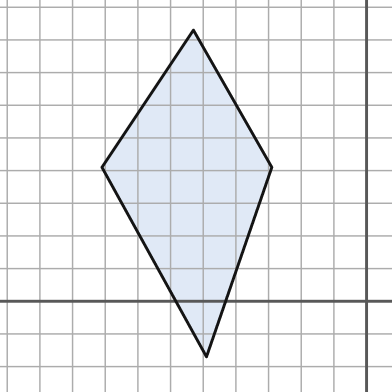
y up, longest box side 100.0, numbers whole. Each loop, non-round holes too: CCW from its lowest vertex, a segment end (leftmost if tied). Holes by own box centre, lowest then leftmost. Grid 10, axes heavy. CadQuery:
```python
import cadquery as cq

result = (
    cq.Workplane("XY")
    .moveTo(-49.0, -17.0)
    .lineTo(-29.0, 41.0)
    .lineTo(-53.0, 83.0)
    .lineTo(-81.0, 41.0)
    .close()
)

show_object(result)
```